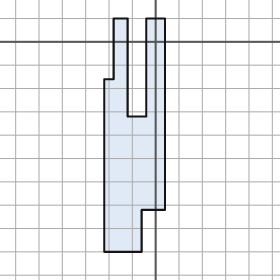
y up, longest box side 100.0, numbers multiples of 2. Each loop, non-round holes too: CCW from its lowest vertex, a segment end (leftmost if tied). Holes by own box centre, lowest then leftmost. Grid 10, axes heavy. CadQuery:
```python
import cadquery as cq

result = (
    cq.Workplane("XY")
    .moveTo(-22.0, -90.0)
    .lineTo(-6.0, -90.0)
    .lineTo(-6.0, -72.0)
    .lineTo(4.0, -72.0)
    .lineTo(4.0, 10.0)
    .lineTo(-4.0, 10.0)
    .lineTo(-4.0, -32.0)
    .lineTo(-12.0, -32.0)
    .lineTo(-12.0, 10.0)
    .lineTo(-18.0, 10.0)
    .lineTo(-18.0, -16.0)
    .lineTo(-22.0, -16.0)
    .close()
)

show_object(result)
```